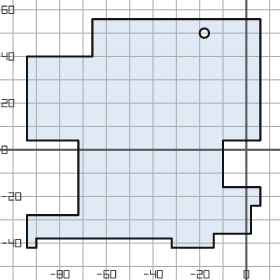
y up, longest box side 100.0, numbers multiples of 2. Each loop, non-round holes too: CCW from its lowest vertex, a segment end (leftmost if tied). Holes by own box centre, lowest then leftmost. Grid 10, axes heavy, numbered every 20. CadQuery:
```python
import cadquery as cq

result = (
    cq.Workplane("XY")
    .moveTo(-94.0, -42.0)
    .lineTo(-90.0, -42.0)
    .lineTo(-90.0, -38.0)
    .lineTo(-32.0, -38.0)
    .lineTo(-32.0, -42.0)
    .lineTo(-14.0, -42.0)
    .lineTo(-14.0, -36.0)
    .lineTo(2.0, -36.0)
    .lineTo(2.0, -24.0)
    .lineTo(6.0, -24.0)
    .lineTo(6.0, -16.0)
    .lineTo(-10.0, -16.0)
    .lineTo(-10.0, 4.0)
    .lineTo(6.0, 4.0)
    .lineTo(6.0, 56.0)
    .lineTo(-66.0, 56.0)
    .lineTo(-66.0, 40.0)
    .lineTo(-94.0, 40.0)
    .lineTo(-94.0, 4.0)
    .lineTo(-72.0, 4.0)
    .lineTo(-72.0, -28.0)
    .lineTo(-94.0, -28.0)
    .close()
    .moveTo(-18.0, 50.0)
    .circle(2.0)
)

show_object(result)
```